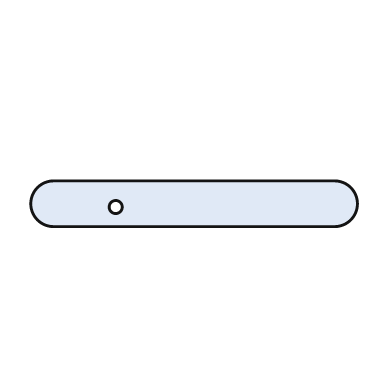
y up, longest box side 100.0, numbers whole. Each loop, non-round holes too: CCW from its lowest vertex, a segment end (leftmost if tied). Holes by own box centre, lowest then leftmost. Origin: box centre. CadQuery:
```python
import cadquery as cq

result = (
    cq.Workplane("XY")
    .moveTo(-43.0, -7.0)
    .lineTo(43.0, -7.0)
    .threePointArc((50.0, 0.0), (43.0, 7.0))
    .lineTo(-43.0, 7.0)
    .threePointArc((-50.0, 0.0), (-43.0, -7.0))
    .close()
    .moveTo(-24.0, -1.0)
    .circle(2.0)
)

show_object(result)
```